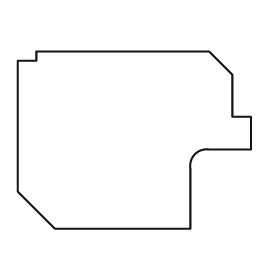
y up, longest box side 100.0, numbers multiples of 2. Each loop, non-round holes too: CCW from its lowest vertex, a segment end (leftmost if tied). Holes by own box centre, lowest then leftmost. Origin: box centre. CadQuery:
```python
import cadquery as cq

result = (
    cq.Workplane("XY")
    .moveTo(-34.0, -38.0)
    .lineTo(24.0, -38.0)
    .lineTo(24.0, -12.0)
    .threePointArc((26.0, -6.0), (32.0, -4.0))
    .lineTo(50.0, -4.0)
    .lineTo(50.0, 10.0)
    .lineTo(42.0, 10.0)
    .lineTo(42.0, 28.0)
    .lineTo(32.0, 38.0)
    .lineTo(-42.0, 38.0)
    .lineTo(-42.0, 34.0)
    .lineTo(-50.0, 34.0)
    .lineTo(-50.0, -22.0)
    .close()
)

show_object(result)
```